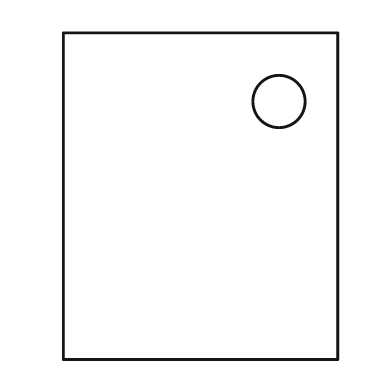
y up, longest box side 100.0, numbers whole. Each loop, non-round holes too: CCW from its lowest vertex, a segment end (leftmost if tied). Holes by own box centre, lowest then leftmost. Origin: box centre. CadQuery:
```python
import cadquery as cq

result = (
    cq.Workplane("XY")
    .moveTo(-42.0, -50.0)
    .lineTo(42.0, -50.0)
    .lineTo(42.0, 50.0)
    .lineTo(-42.0, 50.0)
    .close()
    .moveTo(24.0, 29.0)
    .circle(8.0)
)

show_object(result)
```